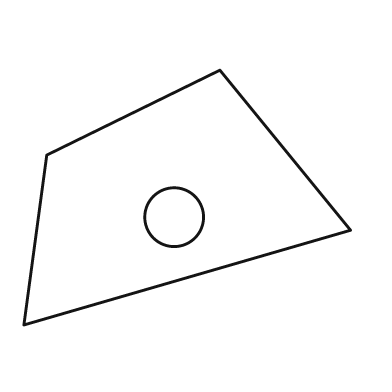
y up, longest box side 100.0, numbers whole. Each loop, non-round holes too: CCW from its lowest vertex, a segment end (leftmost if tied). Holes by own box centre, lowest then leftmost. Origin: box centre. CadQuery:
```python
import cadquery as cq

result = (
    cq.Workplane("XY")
    .moveTo(-50.0, -39.0)
    .lineTo(50.0, -10.0)
    .lineTo(10.0, 39.0)
    .lineTo(-43.0, 13.0)
    .close()
    .moveTo(-4.0, -6.0)
    .circle(9.0)
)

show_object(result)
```